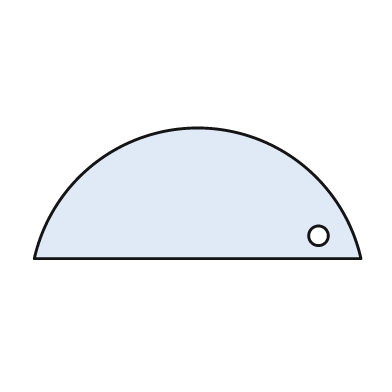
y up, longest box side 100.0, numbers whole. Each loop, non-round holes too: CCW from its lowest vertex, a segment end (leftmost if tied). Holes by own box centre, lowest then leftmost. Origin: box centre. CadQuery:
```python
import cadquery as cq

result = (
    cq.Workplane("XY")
    .moveTo(-50.0, -20.0)
    .lineTo(50.0, -20.0)
    .threePointArc((0.0, 20.0), (-50.0, -20.0))
    .close()
    .moveTo(37.0, -13.0)
    .circle(3.0)
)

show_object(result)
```